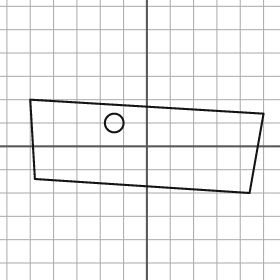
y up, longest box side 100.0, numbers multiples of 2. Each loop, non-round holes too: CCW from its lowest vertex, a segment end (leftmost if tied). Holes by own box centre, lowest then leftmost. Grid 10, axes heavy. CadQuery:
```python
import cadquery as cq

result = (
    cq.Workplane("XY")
    .moveTo(44.0, -20.0)
    .lineTo(50.0, 14.0)
    .lineTo(-50.0, 20.0)
    .lineTo(-48.0, -14.0)
    .close()
    .moveTo(-14.0, 10.0)
    .circle(4.0)
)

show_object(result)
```